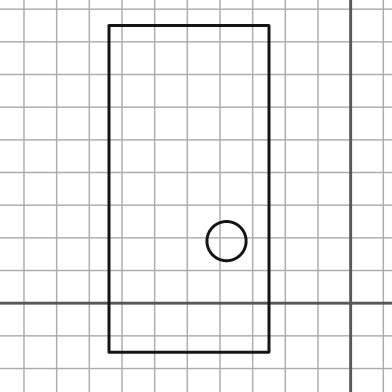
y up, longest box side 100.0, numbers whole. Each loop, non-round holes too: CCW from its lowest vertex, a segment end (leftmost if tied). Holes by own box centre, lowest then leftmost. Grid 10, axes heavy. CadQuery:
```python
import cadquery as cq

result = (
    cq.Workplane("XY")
    .moveTo(-74.0, -15.0)
    .lineTo(-25.0, -15.0)
    .lineTo(-25.0, 85.0)
    .lineTo(-74.0, 85.0)
    .close()
    .moveTo(-38.0, 19.0)
    .circle(6.0)
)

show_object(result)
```